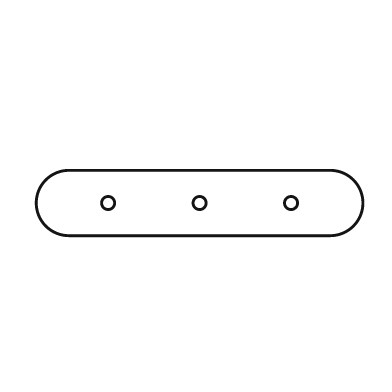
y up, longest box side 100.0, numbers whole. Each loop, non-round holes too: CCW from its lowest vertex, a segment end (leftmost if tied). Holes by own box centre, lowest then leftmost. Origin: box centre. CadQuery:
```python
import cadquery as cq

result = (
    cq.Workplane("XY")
    .moveTo(-40.0, -10.0)
    .lineTo(40.0, -10.0)
    .threePointArc((50.0, 0.0), (40.0, 10.0))
    .lineTo(-40.0, 10.0)
    .threePointArc((-50.0, 0.0), (-40.0, -10.0))
    .close()
    .moveTo(-28.0, 0.0)
    .circle(2.0)
    .moveTo(0.0, 0.0)
    .circle(2.0)
    .moveTo(28.0, 0.0)
    .circle(2.0)
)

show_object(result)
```